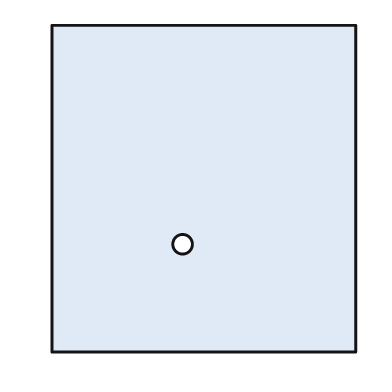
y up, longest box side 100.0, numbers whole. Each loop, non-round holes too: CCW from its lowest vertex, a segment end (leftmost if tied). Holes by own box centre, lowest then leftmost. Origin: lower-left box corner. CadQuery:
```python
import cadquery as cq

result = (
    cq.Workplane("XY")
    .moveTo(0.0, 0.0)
    .lineTo(93.0, 0.0)
    .lineTo(93.0, 100.0)
    .lineTo(0.0, 100.0)
    .close()
    .moveTo(40.0, 33.0)
    .circle(3.0)
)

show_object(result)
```